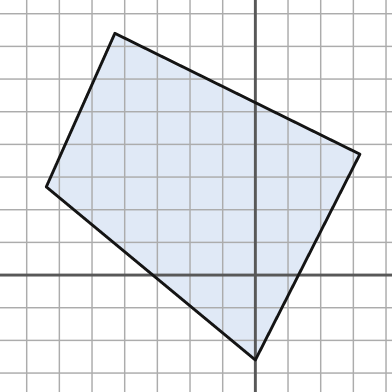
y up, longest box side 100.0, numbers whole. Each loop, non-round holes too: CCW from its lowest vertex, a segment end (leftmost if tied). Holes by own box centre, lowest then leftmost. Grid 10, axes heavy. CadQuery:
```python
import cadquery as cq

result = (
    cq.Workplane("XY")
    .moveTo(0.0, -26.0)
    .lineTo(32.0, 37.0)
    .lineTo(-43.0, 74.0)
    .lineTo(-64.0, 27.0)
    .close()
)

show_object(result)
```